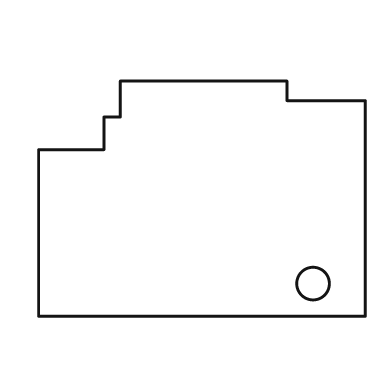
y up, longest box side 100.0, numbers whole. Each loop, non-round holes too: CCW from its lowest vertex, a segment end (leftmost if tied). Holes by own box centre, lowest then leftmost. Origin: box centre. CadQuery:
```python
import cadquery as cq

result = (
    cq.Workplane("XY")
    .moveTo(-50.0, -36.0)
    .lineTo(50.0, -36.0)
    .lineTo(50.0, 30.0)
    .lineTo(26.0, 30.0)
    .lineTo(26.0, 36.0)
    .lineTo(-25.0, 36.0)
    .lineTo(-25.0, 25.0)
    .lineTo(-30.0, 25.0)
    .lineTo(-30.0, 15.0)
    .lineTo(-50.0, 15.0)
    .close()
    .moveTo(34.0, -26.0)
    .circle(5.0)
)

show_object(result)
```